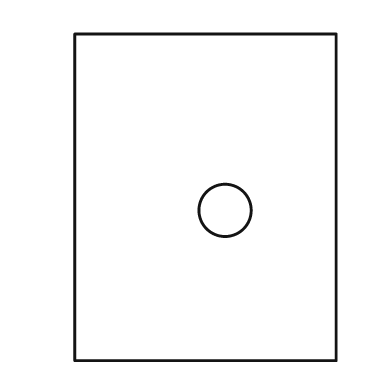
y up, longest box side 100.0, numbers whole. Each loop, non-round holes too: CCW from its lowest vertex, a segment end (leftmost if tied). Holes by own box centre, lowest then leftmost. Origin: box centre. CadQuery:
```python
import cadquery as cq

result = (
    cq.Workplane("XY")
    .moveTo(-40.0, -50.0)
    .lineTo(40.0, -50.0)
    .lineTo(40.0, 50.0)
    .lineTo(-40.0, 50.0)
    .close()
    .moveTo(6.0, -4.0)
    .circle(8.0)
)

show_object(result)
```